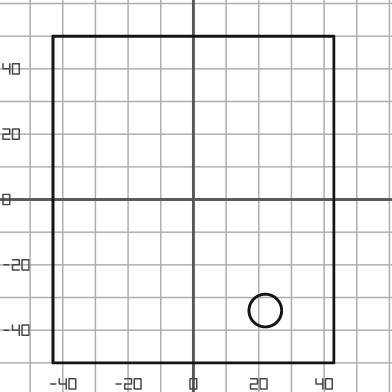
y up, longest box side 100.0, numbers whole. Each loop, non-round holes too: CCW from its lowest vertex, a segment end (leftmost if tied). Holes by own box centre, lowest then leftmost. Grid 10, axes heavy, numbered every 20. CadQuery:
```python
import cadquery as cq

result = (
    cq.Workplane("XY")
    .moveTo(-43.0, -50.0)
    .lineTo(43.0, -50.0)
    .lineTo(43.0, 50.0)
    .lineTo(-43.0, 50.0)
    .close()
    .moveTo(22.0, -34.0)
    .circle(5.0)
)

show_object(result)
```